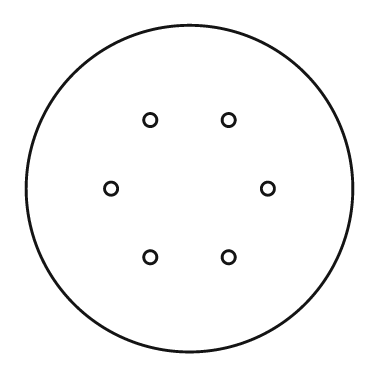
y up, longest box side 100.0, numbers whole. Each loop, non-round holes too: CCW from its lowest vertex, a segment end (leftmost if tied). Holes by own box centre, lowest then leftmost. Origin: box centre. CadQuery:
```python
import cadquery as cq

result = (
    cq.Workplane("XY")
    .moveTo(0.0, 0.0)
    .circle(50.0)
    .moveTo(-12.0, -21.0)
    .circle(2.0)
    .moveTo(12.0, -21.0)
    .circle(2.0)
    .moveTo(-24.0, 0.0)
    .circle(2.0)
    .moveTo(24.0, 0.0)
    .circle(2.0)
    .moveTo(-12.0, 21.0)
    .circle(2.0)
    .moveTo(12.0, 21.0)
    .circle(2.0)
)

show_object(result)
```